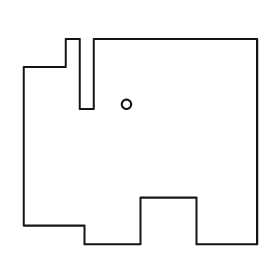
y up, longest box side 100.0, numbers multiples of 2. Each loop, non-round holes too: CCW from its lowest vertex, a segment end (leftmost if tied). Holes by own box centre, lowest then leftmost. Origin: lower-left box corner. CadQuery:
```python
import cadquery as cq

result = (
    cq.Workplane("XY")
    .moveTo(26.0, 0.0)
    .lineTo(50.0, 0.0)
    .lineTo(50.0, 20.0)
    .lineTo(74.0, 20.0)
    .lineTo(74.0, 0.0)
    .lineTo(100.0, 0.0)
    .lineTo(100.0, 88.0)
    .lineTo(30.0, 88.0)
    .lineTo(30.0, 58.0)
    .lineTo(24.0, 58.0)
    .lineTo(24.0, 88.0)
    .lineTo(18.0, 88.0)
    .lineTo(18.0, 76.0)
    .lineTo(0.0, 76.0)
    .lineTo(0.0, 8.0)
    .lineTo(26.0, 8.0)
    .close()
    .moveTo(44.0, 60.0)
    .circle(2.0)
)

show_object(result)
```